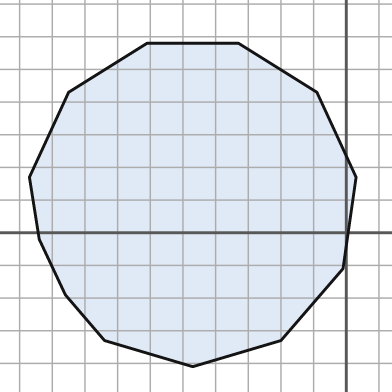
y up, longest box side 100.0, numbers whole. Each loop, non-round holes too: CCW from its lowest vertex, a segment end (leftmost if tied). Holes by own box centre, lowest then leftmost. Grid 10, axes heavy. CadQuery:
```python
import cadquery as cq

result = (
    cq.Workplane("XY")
    .moveTo(-47.0, -41.0)
    .lineTo(-20.0, -33.0)
    .lineTo(-1.0, -11.0)
    .lineTo(3.0, 17.0)
    .lineTo(-9.0, 43.0)
    .lineTo(-33.0, 58.0)
    .lineTo(-61.0, 58.0)
    .lineTo(-85.0, 43.0)
    .lineTo(-97.0, 17.0)
    .lineTo(-94.0, -2.0)
    .lineTo(-86.0, -19.0)
    .lineTo(-74.0, -33.0)
    .close()
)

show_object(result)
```